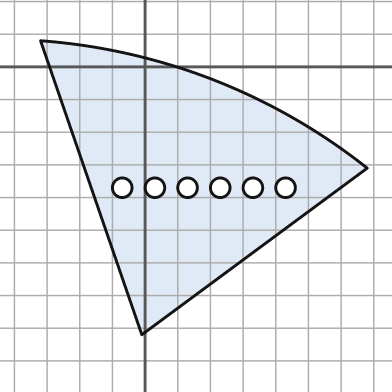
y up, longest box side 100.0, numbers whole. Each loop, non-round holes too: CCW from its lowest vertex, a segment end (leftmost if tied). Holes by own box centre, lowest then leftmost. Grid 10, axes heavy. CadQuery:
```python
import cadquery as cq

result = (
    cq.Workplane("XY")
    .moveTo(-1.0, -82.0)
    .lineTo(68.0, -31.0)
    .threePointArc((21.0, -4.0), (-32.0, 8.0))
    .close()
    .moveTo(-7.0, -37.0)
    .circle(3.0)
    .moveTo(3.0, -37.0)
    .circle(3.0)
    .moveTo(13.0, -37.0)
    .circle(3.0)
    .moveTo(23.0, -37.0)
    .circle(3.0)
    .moveTo(33.0, -37.0)
    .circle(3.0)
    .moveTo(43.0, -37.0)
    .circle(3.0)
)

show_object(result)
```